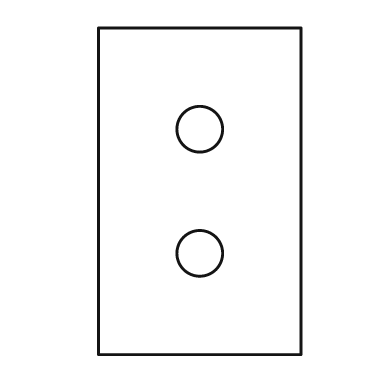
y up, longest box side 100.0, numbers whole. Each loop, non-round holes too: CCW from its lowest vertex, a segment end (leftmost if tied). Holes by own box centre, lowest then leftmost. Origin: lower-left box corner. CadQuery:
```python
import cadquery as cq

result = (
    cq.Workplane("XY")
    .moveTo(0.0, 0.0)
    .lineTo(62.0, 0.0)
    .lineTo(62.0, 100.0)
    .lineTo(0.0, 100.0)
    .close()
    .moveTo(31.0, 31.0)
    .circle(7.0)
    .moveTo(31.0, 69.0)
    .circle(7.0)
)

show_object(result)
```